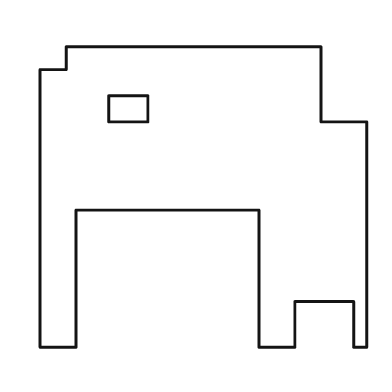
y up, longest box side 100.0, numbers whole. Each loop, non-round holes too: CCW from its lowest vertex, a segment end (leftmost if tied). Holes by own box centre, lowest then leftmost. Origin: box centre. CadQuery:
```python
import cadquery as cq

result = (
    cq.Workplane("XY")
    .moveTo(-50.0, -46.0)
    .lineTo(-39.0, -46.0)
    .lineTo(-39.0, -4.0)
    .lineTo(17.0, -4.0)
    .lineTo(17.0, -46.0)
    .lineTo(28.0, -46.0)
    .lineTo(28.0, -32.0)
    .lineTo(46.0, -32.0)
    .lineTo(46.0, -46.0)
    .lineTo(50.0, -46.0)
    .lineTo(50.0, 23.0)
    .lineTo(36.0, 23.0)
    .lineTo(36.0, 46.0)
    .lineTo(-42.0, 46.0)
    .lineTo(-42.0, 39.0)
    .lineTo(-50.0, 39.0)
    .close()
    .moveTo(-29.0, 23.0)
    .lineTo(-17.0, 23.0)
    .lineTo(-17.0, 31.0)
    .lineTo(-29.0, 31.0)
    .close()
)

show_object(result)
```